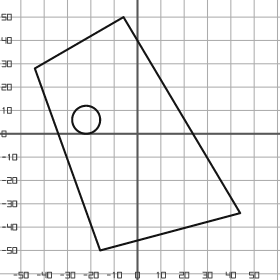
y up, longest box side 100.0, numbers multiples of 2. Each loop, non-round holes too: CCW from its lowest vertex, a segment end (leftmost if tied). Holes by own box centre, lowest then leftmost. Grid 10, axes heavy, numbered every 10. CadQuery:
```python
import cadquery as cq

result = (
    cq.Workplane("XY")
    .moveTo(-16.0, -50.0)
    .lineTo(44.0, -34.0)
    .lineTo(-6.0, 50.0)
    .lineTo(-44.0, 28.0)
    .close()
    .moveTo(-22.0, 6.0)
    .circle(6.0)
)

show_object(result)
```